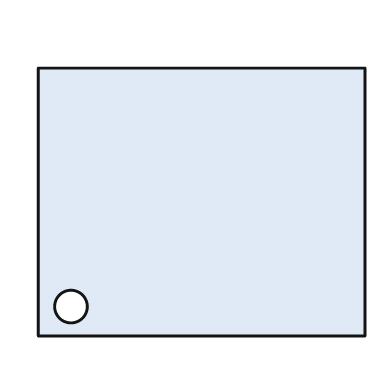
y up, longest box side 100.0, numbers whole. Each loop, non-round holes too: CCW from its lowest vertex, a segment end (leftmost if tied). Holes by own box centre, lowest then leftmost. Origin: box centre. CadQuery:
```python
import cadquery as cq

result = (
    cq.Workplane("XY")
    .moveTo(-50.0, -41.0)
    .lineTo(50.0, -41.0)
    .lineTo(50.0, 41.0)
    .lineTo(-50.0, 41.0)
    .close()
    .moveTo(-40.0, -32.0)
    .circle(5.0)
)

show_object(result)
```